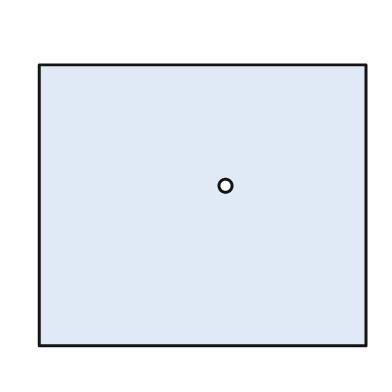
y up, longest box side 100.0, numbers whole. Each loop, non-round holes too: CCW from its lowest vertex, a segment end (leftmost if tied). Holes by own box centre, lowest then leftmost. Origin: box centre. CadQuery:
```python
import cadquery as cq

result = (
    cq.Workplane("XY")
    .moveTo(-50.0, -43.0)
    .lineTo(50.0, -43.0)
    .lineTo(50.0, 43.0)
    .lineTo(-50.0, 43.0)
    .close()
    .moveTo(7.0, 6.0)
    .circle(2.0)
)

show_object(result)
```